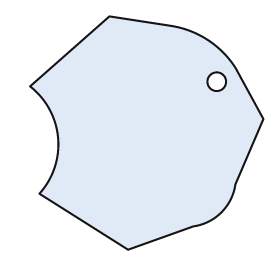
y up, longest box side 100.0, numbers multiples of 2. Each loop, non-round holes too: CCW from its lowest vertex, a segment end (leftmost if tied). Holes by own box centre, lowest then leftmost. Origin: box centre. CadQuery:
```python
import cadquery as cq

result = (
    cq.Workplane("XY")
    .moveTo(-8.0, -50.0)
    .lineTo(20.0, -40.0)
    .threePointArc((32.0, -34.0), (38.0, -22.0))
    .lineTo(50.0, 6.0)
    .lineTo(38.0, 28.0)
    .threePointArc((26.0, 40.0), (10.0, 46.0))
    .lineTo(-16.0, 50.0)
    .lineTo(-50.0, 20.0)
    .threePointArc((-38.0, -2.0), (-46.0, -26.0))
    .close()
    .moveTo(30.0, 22.0)
    .circle(4.0)
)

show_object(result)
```